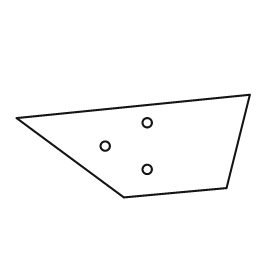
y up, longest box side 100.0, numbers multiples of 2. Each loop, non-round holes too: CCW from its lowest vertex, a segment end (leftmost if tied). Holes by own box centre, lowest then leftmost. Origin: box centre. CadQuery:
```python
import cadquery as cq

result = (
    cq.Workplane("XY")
    .moveTo(-4.0, -22.0)
    .lineTo(40.0, -18.0)
    .lineTo(50.0, 22.0)
    .lineTo(-50.0, 12.0)
    .close()
    .moveTo(6.0, -10.0)
    .circle(2.0)
    .moveTo(-12.0, 0.0)
    .circle(2.0)
    .moveTo(6.0, 10.0)
    .circle(2.0)
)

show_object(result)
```